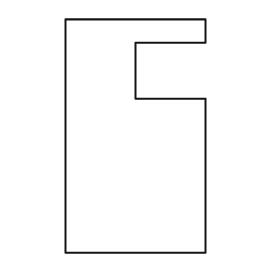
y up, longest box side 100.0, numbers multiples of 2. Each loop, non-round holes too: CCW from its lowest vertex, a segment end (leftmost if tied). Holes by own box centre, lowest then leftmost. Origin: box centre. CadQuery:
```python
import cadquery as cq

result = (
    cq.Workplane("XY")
    .moveTo(-30.0, -50.0)
    .lineTo(30.0, -50.0)
    .lineTo(30.0, 16.0)
    .lineTo(0.0, 16.0)
    .lineTo(0.0, 40.0)
    .lineTo(30.0, 40.0)
    .lineTo(30.0, 50.0)
    .lineTo(-30.0, 50.0)
    .close()
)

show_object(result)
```